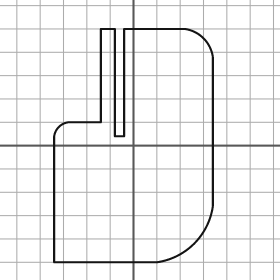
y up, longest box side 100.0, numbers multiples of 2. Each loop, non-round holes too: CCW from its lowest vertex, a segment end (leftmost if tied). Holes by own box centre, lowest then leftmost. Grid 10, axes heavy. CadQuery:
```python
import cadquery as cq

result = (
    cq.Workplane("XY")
    .moveTo(-34.0, -50.0)
    .lineTo(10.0, -50.0)
    .threePointArc((26.0, -42.0), (34.0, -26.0))
    .lineTo(34.0, 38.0)
    .threePointArc((30.0, 46.0), (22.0, 50.0))
    .lineTo(-4.0, 50.0)
    .lineTo(-4.0, 4.0)
    .lineTo(-8.0, 4.0)
    .lineTo(-8.0, 50.0)
    .lineTo(-14.0, 50.0)
    .lineTo(-14.0, 10.0)
    .lineTo(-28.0, 10.0)
    .threePointArc((-32.0, 8.0), (-34.0, 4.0))
    .close()
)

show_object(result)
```